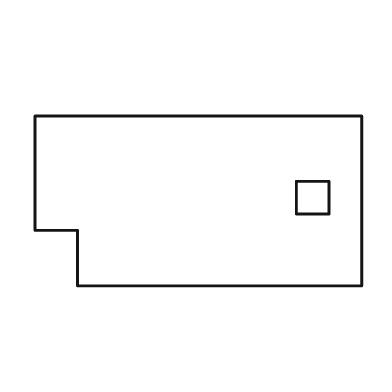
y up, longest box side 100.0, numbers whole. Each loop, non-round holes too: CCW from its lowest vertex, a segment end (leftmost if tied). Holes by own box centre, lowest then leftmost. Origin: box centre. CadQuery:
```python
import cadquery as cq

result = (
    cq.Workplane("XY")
    .moveTo(-37.0, -26.0)
    .lineTo(50.0, -26.0)
    .lineTo(50.0, 26.0)
    .lineTo(-50.0, 26.0)
    .lineTo(-50.0, -9.0)
    .lineTo(-37.0, -9.0)
    .close()
    .moveTo(30.0, -4.0)
    .lineTo(40.0, -4.0)
    .lineTo(40.0, 6.0)
    .lineTo(30.0, 6.0)
    .close()
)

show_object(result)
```